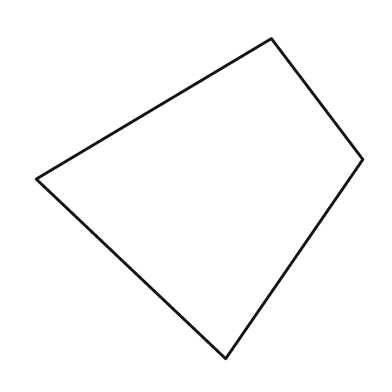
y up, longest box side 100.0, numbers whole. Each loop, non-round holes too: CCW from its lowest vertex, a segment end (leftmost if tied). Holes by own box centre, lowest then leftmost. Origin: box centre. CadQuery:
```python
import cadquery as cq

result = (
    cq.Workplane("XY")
    .moveTo(8.0, -49.0)
    .lineTo(50.0, 12.0)
    .lineTo(22.0, 49.0)
    .lineTo(-50.0, 6.0)
    .close()
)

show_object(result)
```